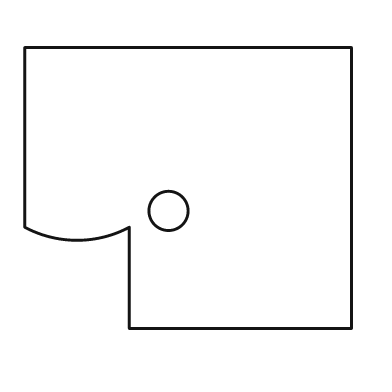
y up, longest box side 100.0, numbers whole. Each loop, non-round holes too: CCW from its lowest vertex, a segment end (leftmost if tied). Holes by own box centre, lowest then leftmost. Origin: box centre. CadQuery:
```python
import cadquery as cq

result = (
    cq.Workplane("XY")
    .moveTo(-18.0, -43.0)
    .lineTo(50.0, -43.0)
    .lineTo(50.0, 43.0)
    .lineTo(-50.0, 43.0)
    .lineTo(-50.0, -12.0)
    .threePointArc((-34.0, -16.0), (-18.0, -12.0))
    .close()
    .moveTo(-6.0, -7.0)
    .circle(6.0)
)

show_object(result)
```